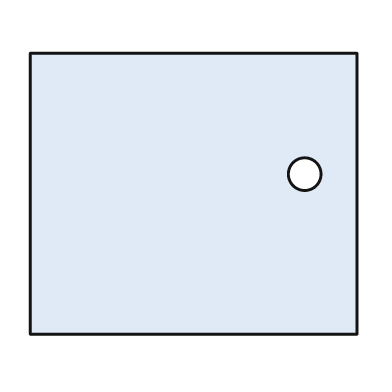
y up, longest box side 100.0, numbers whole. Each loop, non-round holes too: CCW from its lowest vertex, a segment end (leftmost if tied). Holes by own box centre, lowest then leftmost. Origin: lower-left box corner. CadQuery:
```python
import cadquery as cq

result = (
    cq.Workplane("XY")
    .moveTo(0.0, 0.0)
    .lineTo(100.0, 0.0)
    .lineTo(100.0, 86.0)
    .lineTo(0.0, 86.0)
    .close()
    .moveTo(84.0, 49.0)
    .circle(5.0)
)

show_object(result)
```